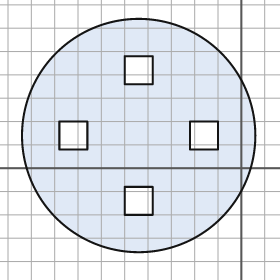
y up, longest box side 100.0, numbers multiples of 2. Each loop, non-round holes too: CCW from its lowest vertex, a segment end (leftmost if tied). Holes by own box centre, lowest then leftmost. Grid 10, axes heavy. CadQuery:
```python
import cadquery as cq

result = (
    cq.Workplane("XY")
    .moveTo(-44.0, 14.0)
    .circle(50.0)
    .moveTo(-50.0, -20.0)
    .lineTo(-38.0, -20.0)
    .lineTo(-38.0, -8.0)
    .lineTo(-50.0, -8.0)
    .close()
    .moveTo(-78.0, 8.0)
    .lineTo(-66.0, 8.0)
    .lineTo(-66.0, 20.0)
    .lineTo(-78.0, 20.0)
    .close()
    .moveTo(-22.0, 8.0)
    .lineTo(-10.0, 8.0)
    .lineTo(-10.0, 20.0)
    .lineTo(-22.0, 20.0)
    .close()
    .moveTo(-50.0, 36.0)
    .lineTo(-38.0, 36.0)
    .lineTo(-38.0, 48.0)
    .lineTo(-50.0, 48.0)
    .close()
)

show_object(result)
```